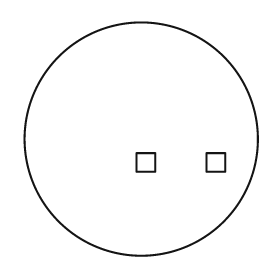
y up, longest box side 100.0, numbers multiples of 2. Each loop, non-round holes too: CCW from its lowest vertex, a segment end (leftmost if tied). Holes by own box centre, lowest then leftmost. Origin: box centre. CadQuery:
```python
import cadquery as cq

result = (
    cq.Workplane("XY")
    .moveTo(0.0, 0.0)
    .circle(50.0)
    .moveTo(-2.0, -14.0)
    .lineTo(6.0, -14.0)
    .lineTo(6.0, -6.0)
    .lineTo(-2.0, -6.0)
    .close()
    .moveTo(28.0, -14.0)
    .lineTo(36.0, -14.0)
    .lineTo(36.0, -6.0)
    .lineTo(28.0, -6.0)
    .close()
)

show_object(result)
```